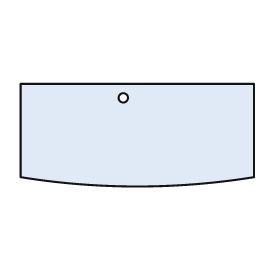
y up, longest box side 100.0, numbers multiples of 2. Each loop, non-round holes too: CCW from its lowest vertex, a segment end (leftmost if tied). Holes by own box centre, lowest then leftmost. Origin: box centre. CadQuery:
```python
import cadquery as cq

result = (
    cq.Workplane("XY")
    .moveTo(-50.0, -18.0)
    .threePointArc((0.0, -22.0), (50.0, -18.0))
    .lineTo(50.0, 22.0)
    .lineTo(-50.0, 22.0)
    .close()
    .moveTo(-6.0, 16.0)
    .circle(2.0)
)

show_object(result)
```